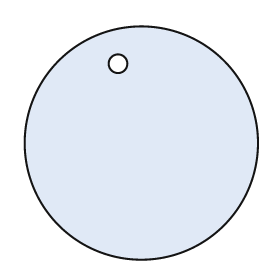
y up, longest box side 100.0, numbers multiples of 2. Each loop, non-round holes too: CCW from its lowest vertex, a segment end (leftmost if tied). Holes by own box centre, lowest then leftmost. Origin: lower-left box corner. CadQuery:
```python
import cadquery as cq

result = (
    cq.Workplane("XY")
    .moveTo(50.0, 50.0)
    .circle(50.0)
    .moveTo(40.0, 84.0)
    .circle(4.0)
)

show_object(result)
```